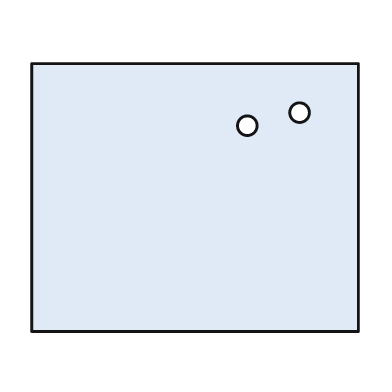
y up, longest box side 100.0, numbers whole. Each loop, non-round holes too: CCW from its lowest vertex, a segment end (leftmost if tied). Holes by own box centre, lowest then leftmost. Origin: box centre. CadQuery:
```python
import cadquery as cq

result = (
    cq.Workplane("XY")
    .moveTo(-50.0, -41.0)
    .lineTo(50.0, -41.0)
    .lineTo(50.0, 41.0)
    .lineTo(-50.0, 41.0)
    .close()
    .moveTo(16.0, 22.0)
    .circle(3.0)
    .moveTo(32.0, 26.0)
    .circle(3.0)
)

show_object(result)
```